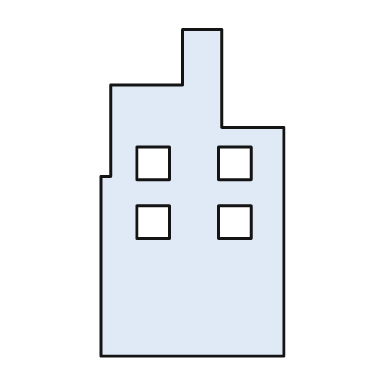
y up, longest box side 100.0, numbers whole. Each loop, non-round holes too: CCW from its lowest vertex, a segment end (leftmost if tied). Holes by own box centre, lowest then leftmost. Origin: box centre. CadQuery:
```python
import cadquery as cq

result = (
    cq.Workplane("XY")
    .moveTo(-28.0, -50.0)
    .lineTo(28.0, -50.0)
    .lineTo(28.0, 20.0)
    .lineTo(9.0, 20.0)
    .lineTo(9.0, 50.0)
    .lineTo(-3.0, 50.0)
    .lineTo(-3.0, 33.0)
    .lineTo(-25.0, 33.0)
    .lineTo(-25.0, 5.0)
    .lineTo(-28.0, 5.0)
    .close()
    .moveTo(-17.0, -14.0)
    .lineTo(-7.0, -14.0)
    .lineTo(-7.0, -4.0)
    .lineTo(-17.0, -4.0)
    .close()
    .moveTo(8.0, -14.0)
    .lineTo(18.0, -14.0)
    .lineTo(18.0, -4.0)
    .lineTo(8.0, -4.0)
    .close()
    .moveTo(-17.0, 4.0)
    .lineTo(-7.0, 4.0)
    .lineTo(-7.0, 14.0)
    .lineTo(-17.0, 14.0)
    .close()
    .moveTo(8.0, 4.0)
    .lineTo(18.0, 4.0)
    .lineTo(18.0, 14.0)
    .lineTo(8.0, 14.0)
    .close()
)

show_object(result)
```